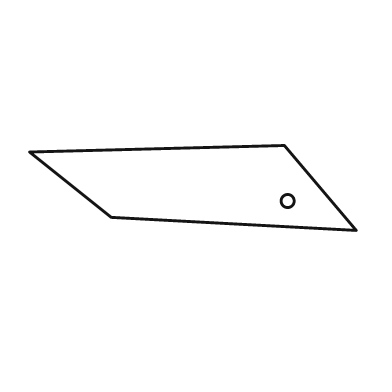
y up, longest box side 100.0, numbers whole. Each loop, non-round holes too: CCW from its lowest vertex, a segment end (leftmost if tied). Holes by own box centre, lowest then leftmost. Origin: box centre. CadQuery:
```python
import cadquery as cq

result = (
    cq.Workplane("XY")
    .moveTo(50.0, -13.0)
    .lineTo(28.0, 13.0)
    .lineTo(-50.0, 11.0)
    .lineTo(-25.0, -9.0)
    .close()
    .moveTo(29.0, -4.0)
    .circle(2.0)
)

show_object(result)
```